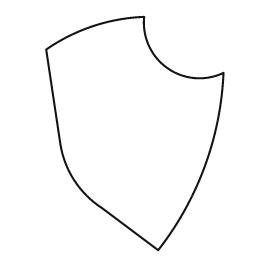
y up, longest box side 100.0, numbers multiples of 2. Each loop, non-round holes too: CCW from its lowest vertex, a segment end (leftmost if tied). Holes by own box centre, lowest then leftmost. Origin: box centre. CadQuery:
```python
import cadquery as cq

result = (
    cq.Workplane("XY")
    .moveTo(10.0, -50.0)
    .threePointArc((30.0, -14.0), (38.0, 26.0))
    .threePointArc((14.0, 28.0), (4.0, 50.0))
    .threePointArc((-18.0, 46.0), (-38.0, 36.0))
    .lineTo(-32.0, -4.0)
    .threePointArc((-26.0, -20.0), (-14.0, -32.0))
    .close()
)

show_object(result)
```